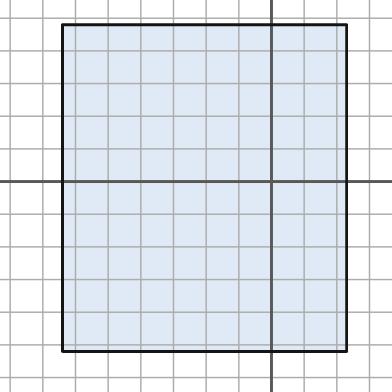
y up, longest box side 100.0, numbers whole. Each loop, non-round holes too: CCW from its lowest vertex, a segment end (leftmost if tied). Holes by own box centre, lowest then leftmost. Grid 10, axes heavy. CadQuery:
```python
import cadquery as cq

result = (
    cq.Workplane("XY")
    .moveTo(-64.0, -52.0)
    .lineTo(23.0, -52.0)
    .lineTo(23.0, 48.0)
    .lineTo(-64.0, 48.0)
    .close()
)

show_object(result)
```